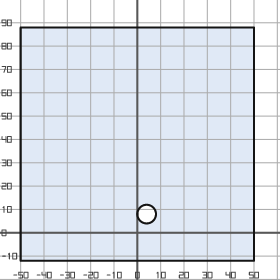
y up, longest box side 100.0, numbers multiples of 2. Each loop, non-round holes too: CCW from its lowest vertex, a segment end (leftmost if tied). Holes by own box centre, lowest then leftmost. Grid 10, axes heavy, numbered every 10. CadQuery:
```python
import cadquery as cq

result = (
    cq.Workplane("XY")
    .moveTo(-50.0, -12.0)
    .lineTo(50.0, -12.0)
    .lineTo(50.0, 88.0)
    .lineTo(-50.0, 88.0)
    .close()
    .moveTo(4.0, 8.0)
    .circle(4.0)
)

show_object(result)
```